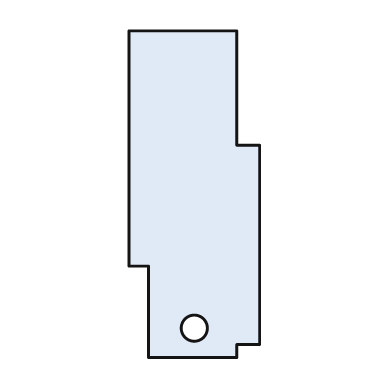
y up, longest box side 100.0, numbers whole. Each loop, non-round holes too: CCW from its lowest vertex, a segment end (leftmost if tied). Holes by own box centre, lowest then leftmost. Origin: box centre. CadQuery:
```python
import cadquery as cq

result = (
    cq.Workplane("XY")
    .moveTo(-14.0, -50.0)
    .lineTo(13.0, -50.0)
    .lineTo(13.0, -46.0)
    .lineTo(20.0, -46.0)
    .lineTo(20.0, 15.0)
    .lineTo(13.0, 15.0)
    .lineTo(13.0, 50.0)
    .lineTo(-20.0, 50.0)
    .lineTo(-20.0, -22.0)
    .lineTo(-14.0, -22.0)
    .close()
    .moveTo(0.0, -41.0)
    .circle(4.0)
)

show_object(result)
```